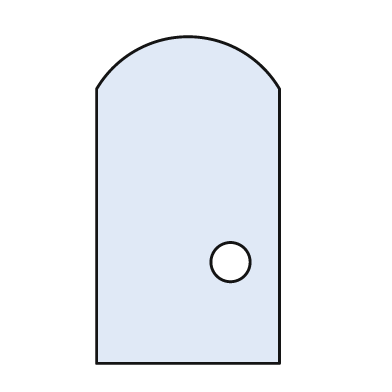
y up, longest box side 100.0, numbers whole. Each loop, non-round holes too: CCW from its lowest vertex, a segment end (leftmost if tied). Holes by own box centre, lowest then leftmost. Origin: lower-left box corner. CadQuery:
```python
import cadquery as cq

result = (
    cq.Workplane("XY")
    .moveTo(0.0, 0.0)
    .lineTo(56.0, 0.0)
    .lineTo(56.0, 84.0)
    .threePointArc((28.0, 100.0), (0.0, 84.0))
    .close()
    .moveTo(41.0, 31.0)
    .circle(6.0)
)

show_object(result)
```